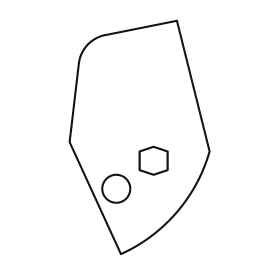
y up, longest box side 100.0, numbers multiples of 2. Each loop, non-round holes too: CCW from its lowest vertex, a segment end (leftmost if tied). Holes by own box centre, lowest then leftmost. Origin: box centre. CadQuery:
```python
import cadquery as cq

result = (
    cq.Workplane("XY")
    .moveTo(-8.0, -50.0)
    .threePointArc((16.0, -32.0), (30.0, -6.0))
    .lineTo(16.0, 50.0)
    .lineTo(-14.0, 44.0)
    .threePointArc((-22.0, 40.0), (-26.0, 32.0))
    .lineTo(-30.0, -2.0)
    .close()
    .moveTo(-10.0, -22.0)
    .circle(6.0)
    .moveTo(6.0, -16.0)
    .lineTo(12.0, -14.0)
    .lineTo(12.0, -6.0)
    .lineTo(6.0, -4.0)
    .lineTo(0.0, -6.0)
    .lineTo(0.0, -14.0)
    .close()
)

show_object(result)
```